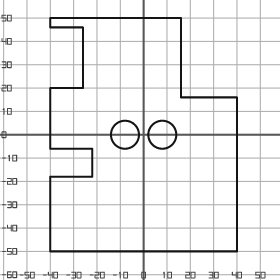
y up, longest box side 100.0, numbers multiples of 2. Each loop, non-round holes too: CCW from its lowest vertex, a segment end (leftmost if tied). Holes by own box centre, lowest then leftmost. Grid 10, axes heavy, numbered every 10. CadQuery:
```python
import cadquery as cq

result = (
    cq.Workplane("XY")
    .moveTo(-40.0, -50.0)
    .lineTo(40.0, -50.0)
    .lineTo(40.0, 16.0)
    .lineTo(16.0, 16.0)
    .lineTo(16.0, 50.0)
    .lineTo(-40.0, 50.0)
    .lineTo(-40.0, 46.0)
    .lineTo(-26.0, 46.0)
    .lineTo(-26.0, 20.0)
    .lineTo(-40.0, 20.0)
    .lineTo(-40.0, -6.0)
    .lineTo(-22.0, -6.0)
    .lineTo(-22.0, -18.0)
    .lineTo(-40.0, -18.0)
    .close()
    .moveTo(-8.0, 0.0)
    .circle(6.0)
    .moveTo(8.0, 0.0)
    .circle(6.0)
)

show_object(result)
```